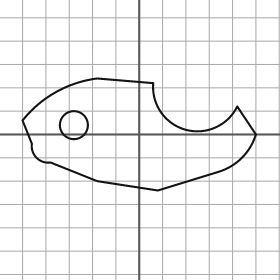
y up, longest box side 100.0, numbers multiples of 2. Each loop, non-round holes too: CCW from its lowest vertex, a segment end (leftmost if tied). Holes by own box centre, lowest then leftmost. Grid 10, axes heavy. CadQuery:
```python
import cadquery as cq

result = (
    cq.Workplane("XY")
    .moveTo(8.0, -24.0)
    .lineTo(34.0, -16.0)
    .threePointArc((44.0, -10.0), (50.0, 0.0))
    .lineTo(42.0, 12.0)
    .threePointArc((20.0, 2.0), (6.0, 22.0))
    .lineTo(-18.0, 24.0)
    .threePointArc((-36.0, 18.0), (-50.0, 6.0))
    .lineTo(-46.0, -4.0)
    .threePointArc((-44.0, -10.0), (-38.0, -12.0))
    .lineTo(-18.0, -20.0)
    .close()
    .moveTo(-28.0, 4.0)
    .circle(6.0)
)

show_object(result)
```